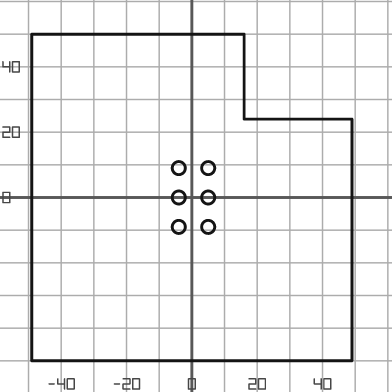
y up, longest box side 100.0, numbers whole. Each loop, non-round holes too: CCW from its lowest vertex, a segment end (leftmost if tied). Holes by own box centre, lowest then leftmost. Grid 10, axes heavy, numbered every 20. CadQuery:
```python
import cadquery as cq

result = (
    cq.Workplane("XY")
    .moveTo(-49.0, -50.0)
    .lineTo(49.0, -50.0)
    .lineTo(49.0, 24.0)
    .lineTo(16.0, 24.0)
    .lineTo(16.0, 50.0)
    .lineTo(-49.0, 50.0)
    .close()
    .moveTo(-4.0, -9.0)
    .circle(2.0)
    .moveTo(5.0, -9.0)
    .circle(2.0)
    .moveTo(-4.0, 0.0)
    .circle(2.0)
    .moveTo(5.0, 0.0)
    .circle(2.0)
    .moveTo(-4.0, 9.0)
    .circle(2.0)
    .moveTo(5.0, 9.0)
    .circle(2.0)
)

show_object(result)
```